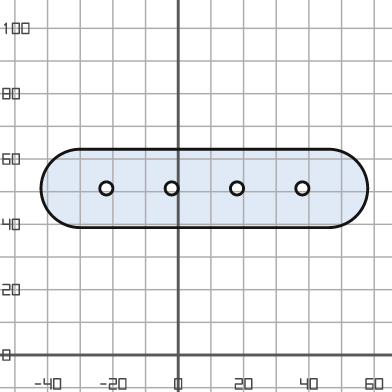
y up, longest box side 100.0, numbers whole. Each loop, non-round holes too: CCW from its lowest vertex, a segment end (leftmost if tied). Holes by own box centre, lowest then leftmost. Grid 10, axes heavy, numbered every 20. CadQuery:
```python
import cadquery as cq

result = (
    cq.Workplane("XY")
    .moveTo(-30.0, 39.0)
    .lineTo(46.0, 39.0)
    .threePointArc((58.0, 51.0), (46.0, 63.0))
    .lineTo(-30.0, 63.0)
    .threePointArc((-42.0, 51.0), (-30.0, 39.0))
    .close()
    .moveTo(-22.0, 51.0)
    .circle(2.0)
    .moveTo(-2.0, 51.0)
    .circle(2.0)
    .moveTo(18.0, 51.0)
    .circle(2.0)
    .moveTo(38.0, 51.0)
    .circle(2.0)
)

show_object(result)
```